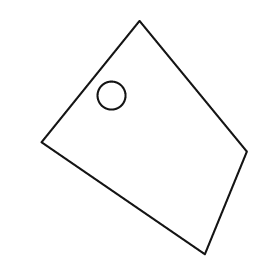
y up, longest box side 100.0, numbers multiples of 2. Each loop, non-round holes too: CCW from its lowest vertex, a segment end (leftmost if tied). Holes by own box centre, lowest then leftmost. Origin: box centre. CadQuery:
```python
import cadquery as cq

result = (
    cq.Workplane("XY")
    .moveTo(26.0, -50.0)
    .lineTo(44.0, -6.0)
    .lineTo(-2.0, 50.0)
    .lineTo(-44.0, -2.0)
    .close()
    .moveTo(-14.0, 18.0)
    .circle(6.0)
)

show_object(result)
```